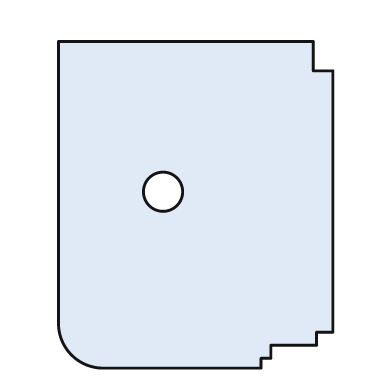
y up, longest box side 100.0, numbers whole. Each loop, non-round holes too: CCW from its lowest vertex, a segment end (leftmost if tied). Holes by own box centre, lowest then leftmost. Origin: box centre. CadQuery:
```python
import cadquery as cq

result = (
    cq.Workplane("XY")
    .moveTo(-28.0, -50.0)
    .lineTo(20.0, -50.0)
    .lineTo(20.0, -47.0)
    .lineTo(23.0, -47.0)
    .lineTo(23.0, -43.0)
    .lineTo(37.0, -43.0)
    .lineTo(37.0, -39.0)
    .lineTo(42.0, -39.0)
    .lineTo(42.0, 41.0)
    .lineTo(36.0, 41.0)
    .lineTo(36.0, 50.0)
    .lineTo(-42.0, 50.0)
    .lineTo(-42.0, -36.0)
    .threePointArc((-38.0, -46.0), (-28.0, -50.0))
    .close()
    .moveTo(-10.0, 4.0)
    .circle(6.0)
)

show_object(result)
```